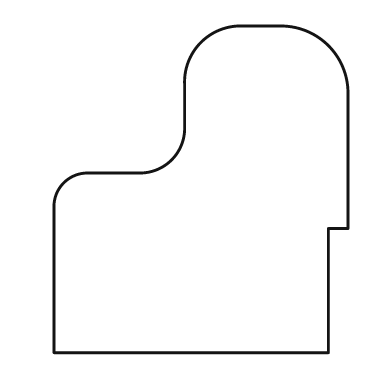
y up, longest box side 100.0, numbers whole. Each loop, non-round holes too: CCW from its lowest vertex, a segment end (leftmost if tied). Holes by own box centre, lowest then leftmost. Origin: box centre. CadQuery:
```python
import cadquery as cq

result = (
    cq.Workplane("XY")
    .moveTo(-45.0, -50.0)
    .lineTo(39.0, -50.0)
    .lineTo(39.0, -12.0)
    .lineTo(45.0, -12.0)
    .lineTo(45.0, 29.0)
    .threePointArc((39.0, 44.0), (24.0, 50.0))
    .lineTo(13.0, 50.0)
    .threePointArc((0.0, 45.0), (-5.0, 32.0))
    .lineTo(-5.0, 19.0)
    .threePointArc((-9.0, 9.0), (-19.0, 5.0))
    .lineTo(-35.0, 5.0)
    .threePointArc((-42.0, 2.0), (-45.0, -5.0))
    .close()
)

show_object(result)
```